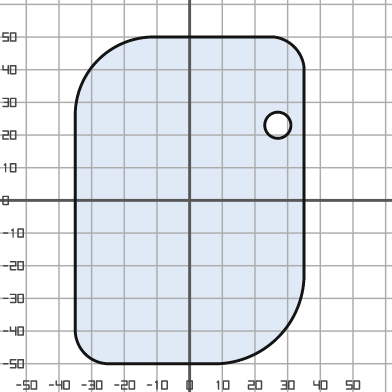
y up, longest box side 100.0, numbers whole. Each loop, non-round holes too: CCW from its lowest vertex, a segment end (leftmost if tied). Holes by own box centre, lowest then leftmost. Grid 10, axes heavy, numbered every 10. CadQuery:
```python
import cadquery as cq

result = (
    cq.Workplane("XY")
    .moveTo(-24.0, -50.0)
    .lineTo(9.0, -50.0)
    .threePointArc((27.0, -42.0), (35.0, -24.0))
    .lineTo(35.0, 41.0)
    .threePointArc((32.0, 47.0), (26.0, 50.0))
    .lineTo(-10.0, 50.0)
    .threePointArc((-28.0, 43.0), (-35.0, 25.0))
    .lineTo(-35.0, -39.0)
    .threePointArc((-32.0, -47.0), (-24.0, -50.0))
    .close()
    .moveTo(27.0, 23.0)
    .circle(4.0)
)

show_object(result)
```